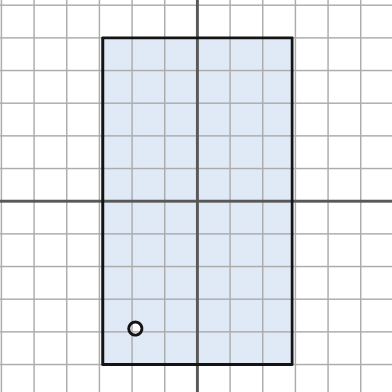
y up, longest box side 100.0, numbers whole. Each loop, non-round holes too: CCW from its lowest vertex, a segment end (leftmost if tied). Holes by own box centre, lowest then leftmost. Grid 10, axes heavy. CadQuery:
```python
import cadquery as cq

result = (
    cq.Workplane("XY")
    .moveTo(-29.0, -50.0)
    .lineTo(29.0, -50.0)
    .lineTo(29.0, 50.0)
    .lineTo(-29.0, 50.0)
    .close()
    .moveTo(-19.0, -39.0)
    .circle(2.0)
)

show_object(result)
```